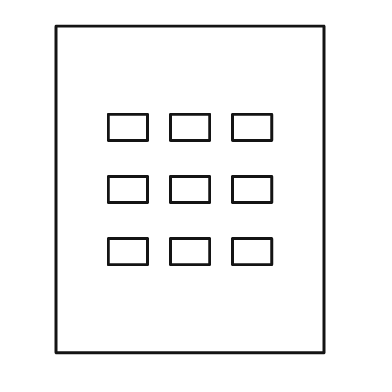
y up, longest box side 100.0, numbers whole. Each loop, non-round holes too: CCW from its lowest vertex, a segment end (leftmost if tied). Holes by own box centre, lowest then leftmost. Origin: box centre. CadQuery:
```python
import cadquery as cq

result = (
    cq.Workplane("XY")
    .moveTo(-41.0, -50.0)
    .lineTo(41.0, -50.0)
    .lineTo(41.0, 50.0)
    .lineTo(-41.0, 50.0)
    .close()
    .moveTo(-25.0, -23.0)
    .lineTo(-13.0, -23.0)
    .lineTo(-13.0, -15.0)
    .lineTo(-25.0, -15.0)
    .close()
    .moveTo(-6.0, -23.0)
    .lineTo(6.0, -23.0)
    .lineTo(6.0, -15.0)
    .lineTo(-6.0, -15.0)
    .close()
    .moveTo(13.0, -23.0)
    .lineTo(25.0, -23.0)
    .lineTo(25.0, -15.0)
    .lineTo(13.0, -15.0)
    .close()
    .moveTo(-25.0, -4.0)
    .lineTo(-13.0, -4.0)
    .lineTo(-13.0, 4.0)
    .lineTo(-25.0, 4.0)
    .close()
    .moveTo(-6.0, -4.0)
    .lineTo(6.0, -4.0)
    .lineTo(6.0, 4.0)
    .lineTo(-6.0, 4.0)
    .close()
    .moveTo(13.0, -4.0)
    .lineTo(25.0, -4.0)
    .lineTo(25.0, 4.0)
    .lineTo(13.0, 4.0)
    .close()
    .moveTo(-25.0, 15.0)
    .lineTo(-13.0, 15.0)
    .lineTo(-13.0, 23.0)
    .lineTo(-25.0, 23.0)
    .close()
    .moveTo(-6.0, 15.0)
    .lineTo(6.0, 15.0)
    .lineTo(6.0, 23.0)
    .lineTo(-6.0, 23.0)
    .close()
    .moveTo(13.0, 15.0)
    .lineTo(25.0, 15.0)
    .lineTo(25.0, 23.0)
    .lineTo(13.0, 23.0)
    .close()
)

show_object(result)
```